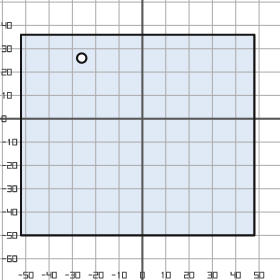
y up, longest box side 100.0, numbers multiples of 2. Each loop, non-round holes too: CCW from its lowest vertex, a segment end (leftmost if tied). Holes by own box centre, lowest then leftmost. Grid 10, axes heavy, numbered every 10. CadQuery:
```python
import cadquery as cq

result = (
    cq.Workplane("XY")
    .moveTo(-52.0, -50.0)
    .lineTo(48.0, -50.0)
    .lineTo(48.0, 36.0)
    .lineTo(-52.0, 36.0)
    .close()
    .moveTo(-26.0, 26.0)
    .circle(2.0)
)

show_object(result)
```